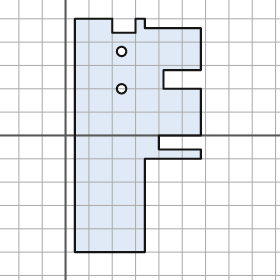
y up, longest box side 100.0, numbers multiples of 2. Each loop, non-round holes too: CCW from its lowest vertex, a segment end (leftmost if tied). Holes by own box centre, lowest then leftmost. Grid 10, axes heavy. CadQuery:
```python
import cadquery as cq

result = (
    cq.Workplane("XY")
    .moveTo(4.0, -50.0)
    .lineTo(34.0, -50.0)
    .lineTo(34.0, -10.0)
    .lineTo(58.0, -10.0)
    .lineTo(58.0, -6.0)
    .lineTo(40.0, -6.0)
    .lineTo(40.0, 0.0)
    .lineTo(58.0, 0.0)
    .lineTo(58.0, 20.0)
    .lineTo(42.0, 20.0)
    .lineTo(42.0, 28.0)
    .lineTo(58.0, 28.0)
    .lineTo(58.0, 46.0)
    .lineTo(34.0, 46.0)
    .lineTo(34.0, 50.0)
    .lineTo(30.0, 50.0)
    .lineTo(30.0, 44.0)
    .lineTo(20.0, 44.0)
    .lineTo(20.0, 50.0)
    .lineTo(4.0, 50.0)
    .close()
    .moveTo(24.0, 20.0)
    .circle(2.0)
    .moveTo(24.0, 36.0)
    .circle(2.0)
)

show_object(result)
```